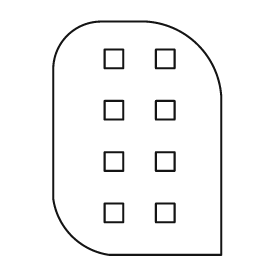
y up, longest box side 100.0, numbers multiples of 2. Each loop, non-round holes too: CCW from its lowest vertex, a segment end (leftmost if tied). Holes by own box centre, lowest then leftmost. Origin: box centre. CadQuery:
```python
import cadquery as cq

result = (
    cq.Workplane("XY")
    .moveTo(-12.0, -50.0)
    .lineTo(36.0, -50.0)
    .lineTo(36.0, 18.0)
    .threePointArc((26.0, 40.0), (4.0, 50.0))
    .lineTo(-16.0, 50.0)
    .threePointArc((-30.0, 44.0), (-36.0, 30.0))
    .lineTo(-36.0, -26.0)
    .threePointArc((-28.0, -42.0), (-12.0, -50.0))
    .close()
    .moveTo(-14.0, -36.0)
    .lineTo(-6.0, -36.0)
    .lineTo(-6.0, -28.0)
    .lineTo(-14.0, -28.0)
    .close()
    .moveTo(8.0, -36.0)
    .lineTo(16.0, -36.0)
    .lineTo(16.0, -28.0)
    .lineTo(8.0, -28.0)
    .close()
    .moveTo(-14.0, -14.0)
    .lineTo(-6.0, -14.0)
    .lineTo(-6.0, -6.0)
    .lineTo(-14.0, -6.0)
    .close()
    .moveTo(8.0, -14.0)
    .lineTo(16.0, -14.0)
    .lineTo(16.0, -6.0)
    .lineTo(8.0, -6.0)
    .close()
    .moveTo(-14.0, 8.0)
    .lineTo(-6.0, 8.0)
    .lineTo(-6.0, 16.0)
    .lineTo(-14.0, 16.0)
    .close()
    .moveTo(8.0, 8.0)
    .lineTo(16.0, 8.0)
    .lineTo(16.0, 16.0)
    .lineTo(8.0, 16.0)
    .close()
    .moveTo(-14.0, 30.0)
    .lineTo(-6.0, 30.0)
    .lineTo(-6.0, 38.0)
    .lineTo(-14.0, 38.0)
    .close()
    .moveTo(8.0, 30.0)
    .lineTo(16.0, 30.0)
    .lineTo(16.0, 38.0)
    .lineTo(8.0, 38.0)
    .close()
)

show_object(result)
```